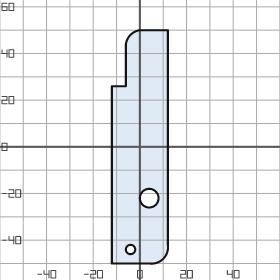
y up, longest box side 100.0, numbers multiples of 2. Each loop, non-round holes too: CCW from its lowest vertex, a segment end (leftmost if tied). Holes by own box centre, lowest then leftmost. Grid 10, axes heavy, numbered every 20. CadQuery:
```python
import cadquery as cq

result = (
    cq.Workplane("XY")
    .moveTo(-12.0, -50.0)
    .lineTo(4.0, -50.0)
    .threePointArc((10.0, -48.0), (12.0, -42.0))
    .lineTo(12.0, 50.0)
    .lineTo(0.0, 50.0)
    .threePointArc((-4.0, 48.0), (-6.0, 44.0))
    .lineTo(-6.0, 26.0)
    .lineTo(-12.0, 26.0)
    .close()
    .moveTo(-4.0, -44.0)
    .circle(2.0)
    .moveTo(4.0, -22.0)
    .circle(4.0)
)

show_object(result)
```